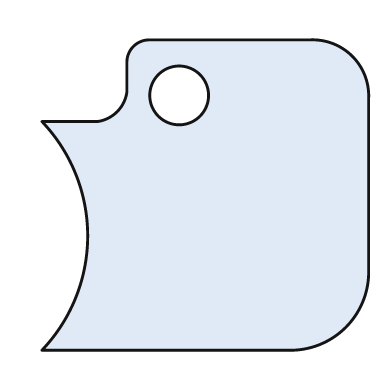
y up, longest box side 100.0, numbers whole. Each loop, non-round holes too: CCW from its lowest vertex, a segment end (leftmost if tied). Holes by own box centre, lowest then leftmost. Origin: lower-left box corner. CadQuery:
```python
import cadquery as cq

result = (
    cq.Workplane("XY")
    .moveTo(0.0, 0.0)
    .lineTo(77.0, 0.0)
    .threePointArc((93.0, 7.0), (100.0, 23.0))
    .lineTo(100.0, 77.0)
    .threePointArc((95.0, 90.0), (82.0, 95.0))
    .lineTo(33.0, 95.0)
    .threePointArc((28.0, 93.0), (26.0, 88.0))
    .lineTo(26.0, 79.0)
    .threePointArc((23.0, 73.0), (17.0, 70.0))
    .lineTo(0.0, 70.0)
    .threePointArc((14.0, 35.0), (0.0, 0.0))
    .close()
    .moveTo(42.0, 78.0)
    .circle(9.0)
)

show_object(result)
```